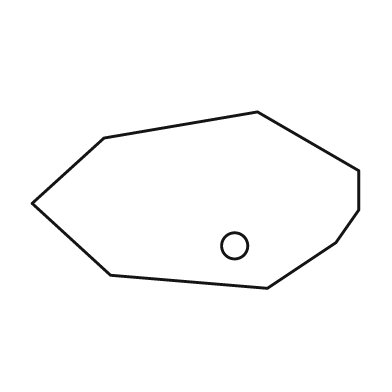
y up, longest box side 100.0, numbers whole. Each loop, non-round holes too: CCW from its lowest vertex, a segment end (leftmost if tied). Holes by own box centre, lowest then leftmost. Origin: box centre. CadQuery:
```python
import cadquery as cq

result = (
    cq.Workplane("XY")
    .moveTo(22.0, -27.0)
    .lineTo(43.0, -13.0)
    .lineTo(50.0, -3.0)
    .lineTo(50.0, 9.0)
    .lineTo(19.0, 27.0)
    .lineTo(-28.0, 19.0)
    .lineTo(-50.0, -1.0)
    .lineTo(-26.0, -23.0)
    .close()
    .moveTo(12.0, -14.0)
    .circle(4.0)
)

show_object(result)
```